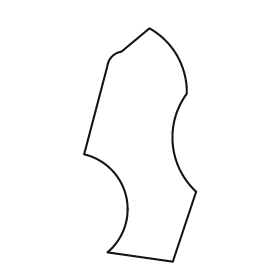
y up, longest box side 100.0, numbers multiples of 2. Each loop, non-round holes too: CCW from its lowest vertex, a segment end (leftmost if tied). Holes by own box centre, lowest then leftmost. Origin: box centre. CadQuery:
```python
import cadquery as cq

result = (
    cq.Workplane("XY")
    .moveTo(14.0, -50.0)
    .lineTo(24.0, -20.0)
    .threePointArc((14.0, 0.0), (20.0, 22.0))
    .threePointArc((16.0, 38.0), (4.0, 50.0))
    .lineTo(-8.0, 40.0)
    .threePointArc((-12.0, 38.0), (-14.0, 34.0))
    .lineTo(-24.0, -4.0)
    .threePointArc((-6.0, -22.0), (-14.0, -46.0))
    .close()
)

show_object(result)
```